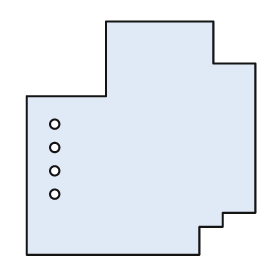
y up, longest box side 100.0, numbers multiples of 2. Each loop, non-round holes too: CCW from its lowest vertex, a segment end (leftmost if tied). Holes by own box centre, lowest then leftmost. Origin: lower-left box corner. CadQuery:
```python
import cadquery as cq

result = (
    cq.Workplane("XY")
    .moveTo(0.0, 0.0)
    .lineTo(74.0, 0.0)
    .lineTo(74.0, 12.0)
    .lineTo(84.0, 12.0)
    .lineTo(84.0, 18.0)
    .lineTo(98.0, 18.0)
    .lineTo(98.0, 82.0)
    .lineTo(80.0, 82.0)
    .lineTo(80.0, 100.0)
    .lineTo(34.0, 100.0)
    .lineTo(34.0, 68.0)
    .lineTo(0.0, 68.0)
    .close()
    .moveTo(12.0, 26.0)
    .circle(2.0)
    .moveTo(12.0, 36.0)
    .circle(2.0)
    .moveTo(12.0, 46.0)
    .circle(2.0)
    .moveTo(12.0, 56.0)
    .circle(2.0)
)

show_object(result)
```